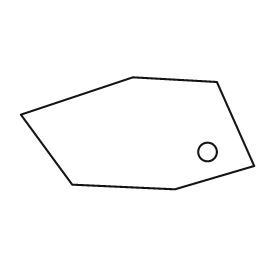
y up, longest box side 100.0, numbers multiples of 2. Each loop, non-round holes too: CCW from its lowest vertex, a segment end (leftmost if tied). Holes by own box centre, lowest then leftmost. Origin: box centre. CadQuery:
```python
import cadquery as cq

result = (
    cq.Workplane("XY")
    .moveTo(16.0, -24.0)
    .lineTo(50.0, -14.0)
    .lineTo(34.0, 22.0)
    .lineTo(-2.0, 24.0)
    .lineTo(-50.0, 8.0)
    .lineTo(-28.0, -22.0)
    .close()
    .moveTo(30.0, -8.0)
    .circle(4.0)
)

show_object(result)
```